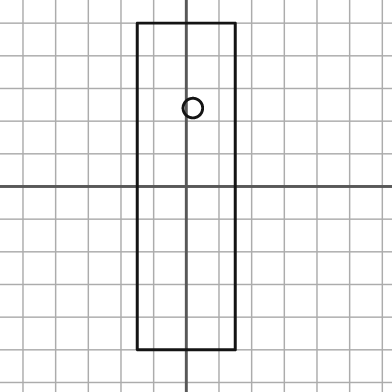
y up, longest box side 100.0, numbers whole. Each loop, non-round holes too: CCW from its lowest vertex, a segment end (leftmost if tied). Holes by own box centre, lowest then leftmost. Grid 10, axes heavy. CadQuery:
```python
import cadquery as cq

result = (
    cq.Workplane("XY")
    .moveTo(-15.0, -50.0)
    .lineTo(15.0, -50.0)
    .lineTo(15.0, 50.0)
    .lineTo(-15.0, 50.0)
    .close()
    .moveTo(2.0, 24.0)
    .circle(3.0)
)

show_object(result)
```